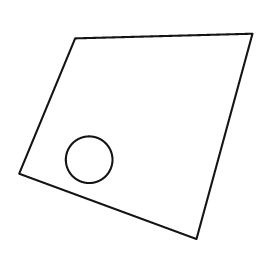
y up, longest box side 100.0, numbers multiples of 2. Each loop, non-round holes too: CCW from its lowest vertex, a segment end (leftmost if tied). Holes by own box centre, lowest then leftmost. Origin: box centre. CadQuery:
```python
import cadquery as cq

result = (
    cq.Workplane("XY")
    .moveTo(26.0, -44.0)
    .lineTo(50.0, 44.0)
    .lineTo(-26.0, 42.0)
    .lineTo(-50.0, -16.0)
    .close()
    .moveTo(-20.0, -10.0)
    .circle(10.0)
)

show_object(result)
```